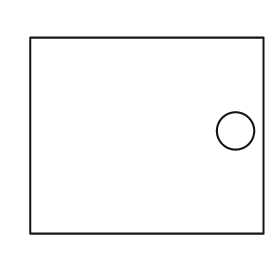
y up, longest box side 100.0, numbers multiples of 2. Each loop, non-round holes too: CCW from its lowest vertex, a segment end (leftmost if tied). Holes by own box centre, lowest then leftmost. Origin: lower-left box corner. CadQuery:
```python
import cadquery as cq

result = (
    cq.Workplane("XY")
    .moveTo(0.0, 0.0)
    .lineTo(100.0, 0.0)
    .lineTo(100.0, 84.0)
    .lineTo(0.0, 84.0)
    .close()
    .moveTo(88.0, 44.0)
    .circle(8.0)
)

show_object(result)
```